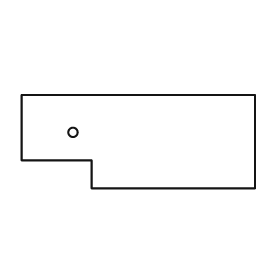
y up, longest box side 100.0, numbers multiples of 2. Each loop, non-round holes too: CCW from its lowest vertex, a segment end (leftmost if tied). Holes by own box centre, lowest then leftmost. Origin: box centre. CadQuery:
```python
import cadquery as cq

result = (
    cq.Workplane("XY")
    .moveTo(-20.0, -20.0)
    .lineTo(50.0, -20.0)
    .lineTo(50.0, 20.0)
    .lineTo(-50.0, 20.0)
    .lineTo(-50.0, -8.0)
    .lineTo(-20.0, -8.0)
    .close()
    .moveTo(-28.0, 4.0)
    .circle(2.0)
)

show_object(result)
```